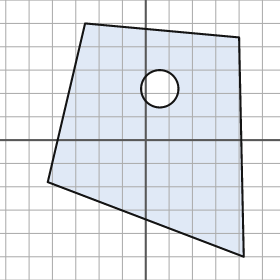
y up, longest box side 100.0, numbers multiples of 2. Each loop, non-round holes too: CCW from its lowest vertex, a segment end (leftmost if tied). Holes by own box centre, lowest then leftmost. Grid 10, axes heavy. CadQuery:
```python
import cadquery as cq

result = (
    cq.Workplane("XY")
    .moveTo(42.0, -50.0)
    .lineTo(40.0, 44.0)
    .lineTo(-26.0, 50.0)
    .lineTo(-42.0, -18.0)
    .close()
    .moveTo(6.0, 22.0)
    .circle(8.0)
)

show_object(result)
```